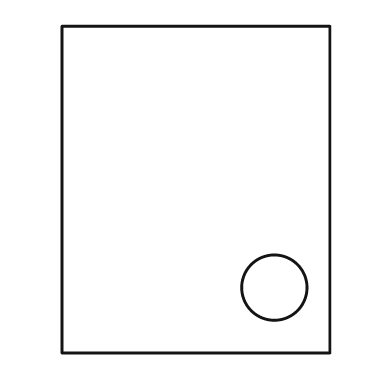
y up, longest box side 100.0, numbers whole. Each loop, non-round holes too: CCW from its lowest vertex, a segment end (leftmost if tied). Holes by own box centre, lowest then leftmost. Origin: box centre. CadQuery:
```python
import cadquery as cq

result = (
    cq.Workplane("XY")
    .moveTo(-41.0, -50.0)
    .lineTo(41.0, -50.0)
    .lineTo(41.0, 50.0)
    .lineTo(-41.0, 50.0)
    .close()
    .moveTo(24.0, -30.0)
    .circle(10.0)
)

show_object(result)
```